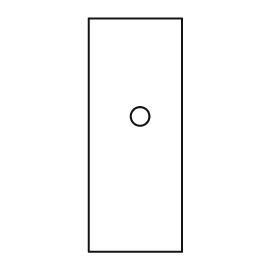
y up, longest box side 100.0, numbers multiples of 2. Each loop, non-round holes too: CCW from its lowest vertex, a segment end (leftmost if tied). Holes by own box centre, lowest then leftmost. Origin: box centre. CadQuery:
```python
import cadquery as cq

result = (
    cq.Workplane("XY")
    .moveTo(-20.0, -50.0)
    .lineTo(20.0, -50.0)
    .lineTo(20.0, 50.0)
    .lineTo(-20.0, 50.0)
    .close()
    .moveTo(2.0, 8.0)
    .circle(4.0)
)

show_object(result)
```